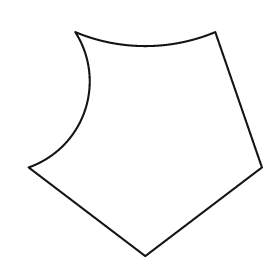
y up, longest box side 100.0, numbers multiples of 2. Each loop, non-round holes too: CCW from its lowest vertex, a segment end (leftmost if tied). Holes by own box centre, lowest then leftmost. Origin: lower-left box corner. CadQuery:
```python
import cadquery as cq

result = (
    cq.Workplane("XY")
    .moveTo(50.0, 0.0)
    .lineTo(100.0, 38.0)
    .lineTo(80.0, 96.0)
    .threePointArc((50.0, 90.0), (20.0, 96.0))
    .threePointArc((24.0, 62.0), (0.0, 38.0))
    .close()
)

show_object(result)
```